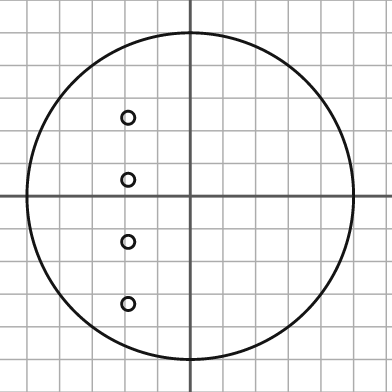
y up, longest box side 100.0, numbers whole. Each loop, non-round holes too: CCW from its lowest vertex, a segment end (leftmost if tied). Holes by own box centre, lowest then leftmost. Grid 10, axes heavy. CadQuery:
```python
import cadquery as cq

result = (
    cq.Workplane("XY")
    .moveTo(0.0, 0.0)
    .circle(50.0)
    .moveTo(-19.0, -33.0)
    .circle(2.0)
    .moveTo(-19.0, -14.0)
    .circle(2.0)
    .moveTo(-19.0, 5.0)
    .circle(2.0)
    .moveTo(-19.0, 24.0)
    .circle(2.0)
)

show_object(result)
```